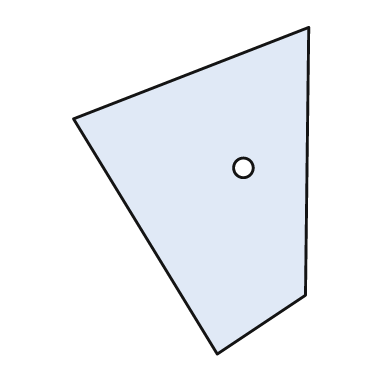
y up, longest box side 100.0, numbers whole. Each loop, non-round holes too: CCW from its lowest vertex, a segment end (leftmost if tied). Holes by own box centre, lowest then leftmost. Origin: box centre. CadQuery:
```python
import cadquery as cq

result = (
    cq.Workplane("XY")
    .moveTo(8.0, -50.0)
    .lineTo(35.0, -32.0)
    .lineTo(36.0, 50.0)
    .lineTo(-36.0, 22.0)
    .close()
    .moveTo(16.0, 7.0)
    .circle(3.0)
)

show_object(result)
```